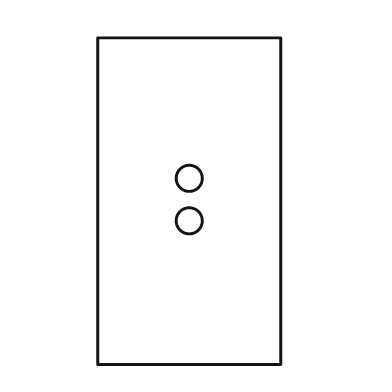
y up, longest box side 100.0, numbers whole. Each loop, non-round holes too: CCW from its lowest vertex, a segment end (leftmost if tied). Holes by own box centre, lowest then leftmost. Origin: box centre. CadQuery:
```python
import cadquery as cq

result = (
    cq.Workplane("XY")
    .moveTo(-28.0, -50.0)
    .lineTo(28.0, -50.0)
    .lineTo(28.0, 50.0)
    .lineTo(-28.0, 50.0)
    .close()
    .moveTo(0.0, -6.0)
    .circle(4.0)
    .moveTo(0.0, 7.0)
    .circle(4.0)
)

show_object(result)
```